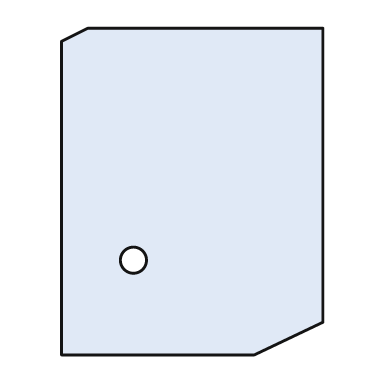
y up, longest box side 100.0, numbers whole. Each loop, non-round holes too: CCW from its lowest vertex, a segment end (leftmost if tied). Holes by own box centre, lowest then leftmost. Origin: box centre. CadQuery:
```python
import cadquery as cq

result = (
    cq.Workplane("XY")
    .moveTo(-40.0, -50.0)
    .lineTo(19.0, -50.0)
    .lineTo(40.0, -40.0)
    .lineTo(40.0, 50.0)
    .lineTo(-32.0, 50.0)
    .lineTo(-40.0, 46.0)
    .close()
    .moveTo(-18.0, -21.0)
    .circle(4.0)
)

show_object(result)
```